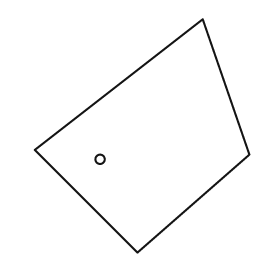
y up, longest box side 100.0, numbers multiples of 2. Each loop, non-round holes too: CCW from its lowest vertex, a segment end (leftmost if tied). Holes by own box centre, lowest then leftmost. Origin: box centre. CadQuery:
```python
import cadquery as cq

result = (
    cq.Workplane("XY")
    .moveTo(-2.0, -50.0)
    .lineTo(46.0, -8.0)
    .lineTo(26.0, 50.0)
    .lineTo(-46.0, -6.0)
    .close()
    .moveTo(-18.0, -10.0)
    .circle(2.0)
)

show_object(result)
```